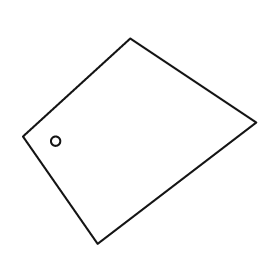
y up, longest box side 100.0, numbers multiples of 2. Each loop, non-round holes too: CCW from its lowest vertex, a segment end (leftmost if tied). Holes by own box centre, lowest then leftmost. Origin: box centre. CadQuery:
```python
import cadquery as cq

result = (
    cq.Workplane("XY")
    .moveTo(-18.0, -44.0)
    .lineTo(50.0, 8.0)
    .lineTo(-4.0, 44.0)
    .lineTo(-50.0, 2.0)
    .close()
    .moveTo(-36.0, 0.0)
    .circle(2.0)
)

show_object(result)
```